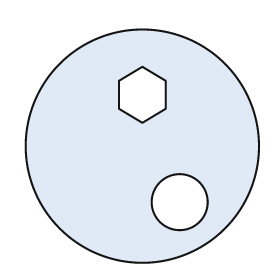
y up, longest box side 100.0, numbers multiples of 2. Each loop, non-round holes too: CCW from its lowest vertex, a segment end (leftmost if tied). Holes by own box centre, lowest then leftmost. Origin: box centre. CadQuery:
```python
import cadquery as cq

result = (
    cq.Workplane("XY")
    .moveTo(0.0, 0.0)
    .circle(50.0)
    .moveTo(16.0, -24.0)
    .circle(12.0)
    .moveTo(0.0, 10.0)
    .lineTo(10.0, 16.0)
    .lineTo(10.0, 28.0)
    .lineTo(0.0, 34.0)
    .lineTo(-10.0, 28.0)
    .lineTo(-10.0, 16.0)
    .close()
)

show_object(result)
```